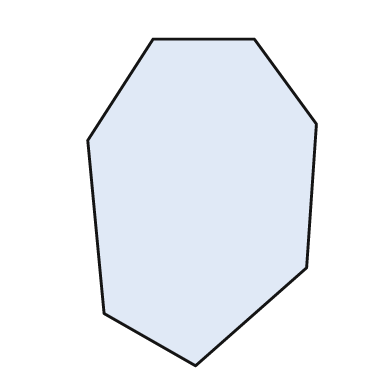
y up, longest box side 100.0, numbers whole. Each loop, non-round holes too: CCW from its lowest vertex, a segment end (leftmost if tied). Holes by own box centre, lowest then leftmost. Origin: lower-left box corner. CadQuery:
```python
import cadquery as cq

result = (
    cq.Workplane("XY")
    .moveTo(33.0, 0.0)
    .lineTo(67.0, 30.0)
    .lineTo(70.0, 74.0)
    .lineTo(51.0, 100.0)
    .lineTo(20.0, 100.0)
    .lineTo(0.0, 69.0)
    .lineTo(5.0, 16.0)
    .close()
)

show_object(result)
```